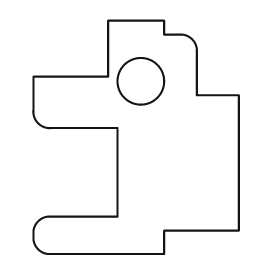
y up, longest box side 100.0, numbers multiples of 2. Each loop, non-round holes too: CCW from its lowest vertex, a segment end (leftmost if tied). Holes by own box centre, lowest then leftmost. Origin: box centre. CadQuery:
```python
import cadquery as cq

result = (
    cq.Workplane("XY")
    .moveTo(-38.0, -50.0)
    .lineTo(12.0, -50.0)
    .lineTo(12.0, -40.0)
    .lineTo(44.0, -40.0)
    .lineTo(44.0, 18.0)
    .lineTo(26.0, 18.0)
    .lineTo(26.0, 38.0)
    .threePointArc((24.0, 42.0), (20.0, 44.0))
    .lineTo(12.0, 44.0)
    .lineTo(12.0, 50.0)
    .lineTo(-12.0, 50.0)
    .lineTo(-12.0, 26.0)
    .lineTo(-44.0, 26.0)
    .lineTo(-44.0, 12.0)
    .threePointArc((-42.0, 6.0), (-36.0, 4.0))
    .lineTo(-8.0, 4.0)
    .lineTo(-8.0, -34.0)
    .lineTo(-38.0, -34.0)
    .threePointArc((-42.0, -36.0), (-44.0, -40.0))
    .lineTo(-44.0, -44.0)
    .threePointArc((-42.0, -48.0), (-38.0, -50.0))
    .close()
    .moveTo(2.0, 24.0)
    .circle(10.0)
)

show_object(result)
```